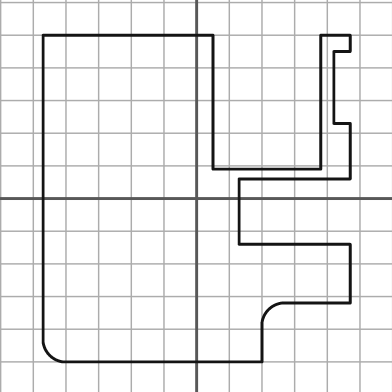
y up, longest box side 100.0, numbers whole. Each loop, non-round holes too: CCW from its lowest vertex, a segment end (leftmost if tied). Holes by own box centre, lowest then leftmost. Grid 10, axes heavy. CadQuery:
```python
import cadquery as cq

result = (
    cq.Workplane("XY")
    .moveTo(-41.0, -50.0)
    .lineTo(20.0, -50.0)
    .lineTo(20.0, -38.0)
    .threePointArc((22.0, -34.0), (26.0, -32.0))
    .lineTo(47.0, -32.0)
    .lineTo(47.0, -14.0)
    .lineTo(13.0, -14.0)
    .lineTo(13.0, 6.0)
    .lineTo(47.0, 6.0)
    .lineTo(47.0, 23.0)
    .lineTo(42.0, 23.0)
    .lineTo(42.0, 45.0)
    .lineTo(47.0, 45.0)
    .lineTo(47.0, 50.0)
    .lineTo(38.0, 50.0)
    .lineTo(38.0, 9.0)
    .lineTo(5.0, 9.0)
    .lineTo(5.0, 50.0)
    .lineTo(-47.0, 50.0)
    .lineTo(-47.0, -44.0)
    .threePointArc((-45.0, -48.0), (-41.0, -50.0))
    .close()
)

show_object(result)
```